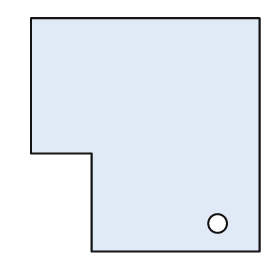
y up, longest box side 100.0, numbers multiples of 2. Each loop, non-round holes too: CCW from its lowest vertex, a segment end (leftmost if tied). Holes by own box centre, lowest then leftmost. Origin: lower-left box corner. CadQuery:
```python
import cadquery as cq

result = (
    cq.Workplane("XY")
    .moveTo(26.0, 0.0)
    .lineTo(98.0, 0.0)
    .lineTo(98.0, 100.0)
    .lineTo(0.0, 100.0)
    .lineTo(0.0, 42.0)
    .lineTo(26.0, 42.0)
    .close()
    .moveTo(80.0, 12.0)
    .circle(4.0)
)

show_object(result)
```